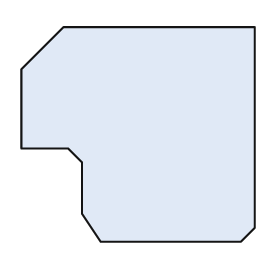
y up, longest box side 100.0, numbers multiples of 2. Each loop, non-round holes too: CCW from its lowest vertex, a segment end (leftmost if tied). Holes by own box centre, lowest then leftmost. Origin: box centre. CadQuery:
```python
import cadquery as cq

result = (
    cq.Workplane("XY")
    .moveTo(-16.0, -46.0)
    .lineTo(44.0, -46.0)
    .lineTo(50.0, -40.0)
    .lineTo(50.0, 46.0)
    .lineTo(-32.0, 46.0)
    .lineTo(-50.0, 28.0)
    .lineTo(-50.0, -6.0)
    .lineTo(-30.0, -6.0)
    .lineTo(-24.0, -12.0)
    .lineTo(-24.0, -34.0)
    .close()
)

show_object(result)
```